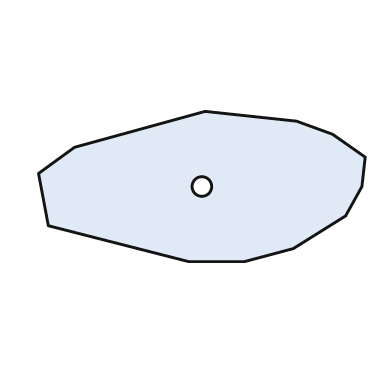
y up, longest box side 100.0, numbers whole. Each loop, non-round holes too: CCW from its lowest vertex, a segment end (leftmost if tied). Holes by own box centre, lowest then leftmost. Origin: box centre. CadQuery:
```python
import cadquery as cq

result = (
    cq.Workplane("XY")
    .moveTo(-4.0, -23.0)
    .lineTo(13.0, -23.0)
    .lineTo(28.0, -19.0)
    .lineTo(44.0, -9.0)
    .lineTo(49.0, 0.0)
    .lineTo(50.0, 9.0)
    .lineTo(40.0, 16.0)
    .lineTo(29.0, 20.0)
    .lineTo(1.0, 23.0)
    .lineTo(-39.0, 12.0)
    .lineTo(-50.0, 4.0)
    .lineTo(-47.0, -12.0)
    .close()
    .moveTo(0.0, 0.0)
    .circle(3.0)
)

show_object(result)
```